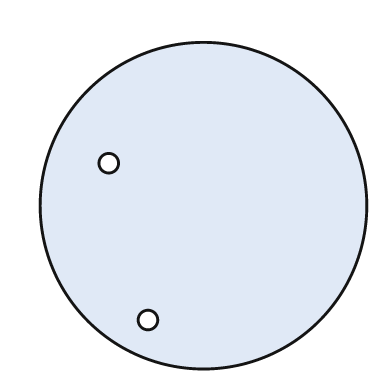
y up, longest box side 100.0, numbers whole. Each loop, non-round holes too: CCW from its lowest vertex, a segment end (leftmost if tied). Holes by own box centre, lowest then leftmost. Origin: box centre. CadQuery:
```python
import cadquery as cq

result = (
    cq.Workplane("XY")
    .moveTo(0.0, 0.0)
    .circle(50.0)
    .moveTo(-17.0, -35.0)
    .circle(3.0)
    .moveTo(-29.0, 13.0)
    .circle(3.0)
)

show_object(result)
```